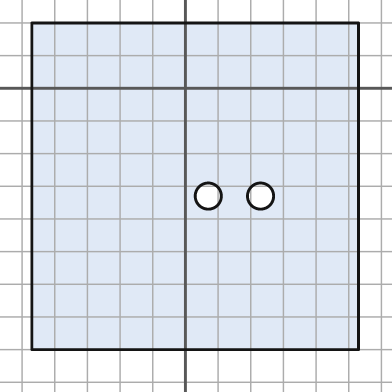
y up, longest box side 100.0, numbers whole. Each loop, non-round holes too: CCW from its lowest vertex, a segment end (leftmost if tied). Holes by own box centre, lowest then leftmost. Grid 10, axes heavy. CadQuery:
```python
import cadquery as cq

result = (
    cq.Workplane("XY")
    .moveTo(-47.0, -80.0)
    .lineTo(53.0, -80.0)
    .lineTo(53.0, 20.0)
    .lineTo(-47.0, 20.0)
    .close()
    .moveTo(7.0, -33.0)
    .circle(4.0)
    .moveTo(23.0, -33.0)
    .circle(4.0)
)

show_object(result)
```